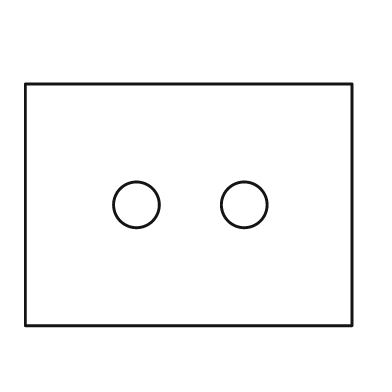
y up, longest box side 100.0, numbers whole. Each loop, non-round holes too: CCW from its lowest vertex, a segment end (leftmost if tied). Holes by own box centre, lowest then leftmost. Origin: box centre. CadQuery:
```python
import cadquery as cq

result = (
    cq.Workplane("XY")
    .moveTo(-50.0, -37.0)
    .lineTo(50.0, -37.0)
    .lineTo(50.0, 37.0)
    .lineTo(-50.0, 37.0)
    .close()
    .moveTo(-16.0, 0.0)
    .circle(7.0)
    .moveTo(17.0, 0.0)
    .circle(7.0)
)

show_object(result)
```